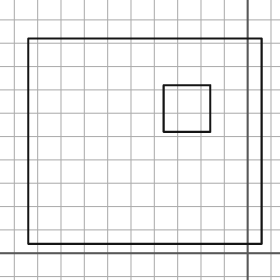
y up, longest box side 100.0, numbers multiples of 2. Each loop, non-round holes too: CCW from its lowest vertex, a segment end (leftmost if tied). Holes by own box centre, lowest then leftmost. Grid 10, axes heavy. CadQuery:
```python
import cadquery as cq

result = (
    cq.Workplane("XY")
    .moveTo(-94.0, 4.0)
    .lineTo(6.0, 4.0)
    .lineTo(6.0, 92.0)
    .lineTo(-94.0, 92.0)
    .close()
    .moveTo(-36.0, 52.0)
    .lineTo(-16.0, 52.0)
    .lineTo(-16.0, 72.0)
    .lineTo(-36.0, 72.0)
    .close()
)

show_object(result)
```